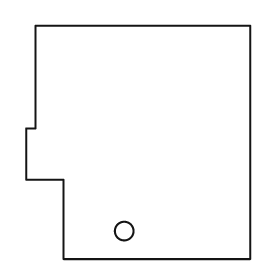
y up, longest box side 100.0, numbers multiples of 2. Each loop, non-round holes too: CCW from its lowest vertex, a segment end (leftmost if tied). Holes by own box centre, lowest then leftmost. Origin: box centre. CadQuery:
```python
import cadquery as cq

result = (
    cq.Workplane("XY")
    .moveTo(-32.0, -50.0)
    .lineTo(48.0, -50.0)
    .lineTo(48.0, 50.0)
    .lineTo(-44.0, 50.0)
    .lineTo(-44.0, 6.0)
    .lineTo(-48.0, 6.0)
    .lineTo(-48.0, -16.0)
    .lineTo(-32.0, -16.0)
    .close()
    .moveTo(-6.0, -38.0)
    .circle(4.0)
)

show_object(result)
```